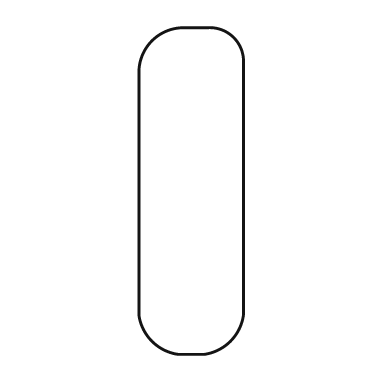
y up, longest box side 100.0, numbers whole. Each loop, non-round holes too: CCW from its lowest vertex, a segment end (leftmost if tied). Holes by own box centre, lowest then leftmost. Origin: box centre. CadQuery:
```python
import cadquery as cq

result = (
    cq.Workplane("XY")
    .moveTo(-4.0, -50.0)
    .lineTo(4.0, -50.0)
    .threePointArc((12.0, -46.0), (16.0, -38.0))
    .lineTo(16.0, 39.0)
    .threePointArc((13.0, 47.0), (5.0, 50.0))
    .lineTo(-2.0, 50.0)
    .threePointArc((-12.0, 46.0), (-16.0, 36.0))
    .lineTo(-16.0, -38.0)
    .threePointArc((-12.0, -46.0), (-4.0, -50.0))
    .close()
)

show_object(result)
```